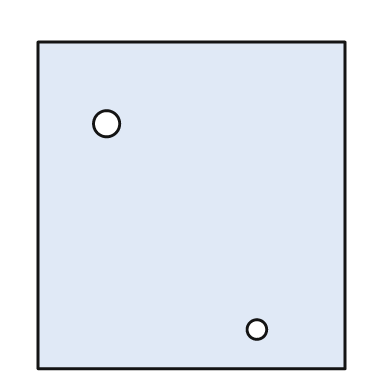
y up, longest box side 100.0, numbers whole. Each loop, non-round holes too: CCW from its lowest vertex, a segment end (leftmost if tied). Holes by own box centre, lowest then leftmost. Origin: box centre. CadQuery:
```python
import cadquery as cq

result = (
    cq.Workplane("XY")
    .moveTo(-47.0, -50.0)
    .lineTo(47.0, -50.0)
    .lineTo(47.0, 50.0)
    .lineTo(-47.0, 50.0)
    .close()
    .moveTo(20.0, -38.0)
    .circle(3.0)
    .moveTo(-26.0, 25.0)
    .circle(4.0)
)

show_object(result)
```